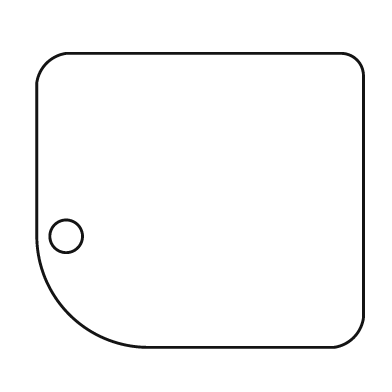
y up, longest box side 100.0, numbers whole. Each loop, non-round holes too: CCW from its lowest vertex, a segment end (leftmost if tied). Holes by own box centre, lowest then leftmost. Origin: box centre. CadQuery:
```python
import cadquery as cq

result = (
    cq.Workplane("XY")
    .moveTo(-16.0, -45.0)
    .lineTo(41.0, -45.0)
    .threePointArc((47.0, -42.0), (50.0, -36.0))
    .lineTo(50.0, 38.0)
    .threePointArc((48.0, 43.0), (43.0, 45.0))
    .lineTo(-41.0, 45.0)
    .threePointArc((-47.0, 42.0), (-50.0, 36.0))
    .lineTo(-50.0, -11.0)
    .threePointArc((-40.0, -35.0), (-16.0, -45.0))
    .close()
    .moveTo(-41.0, -11.0)
    .circle(5.0)
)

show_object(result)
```